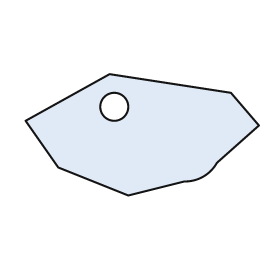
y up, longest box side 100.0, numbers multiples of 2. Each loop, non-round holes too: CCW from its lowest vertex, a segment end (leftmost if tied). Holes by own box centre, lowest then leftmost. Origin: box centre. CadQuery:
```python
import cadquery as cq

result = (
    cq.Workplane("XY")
    .moveTo(-6.0, -26.0)
    .lineTo(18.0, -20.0)
    .threePointArc((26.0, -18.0), (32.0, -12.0))
    .lineTo(50.0, 4.0)
    .lineTo(38.0, 18.0)
    .lineTo(-14.0, 26.0)
    .lineTo(-50.0, 6.0)
    .lineTo(-36.0, -14.0)
    .close()
    .moveTo(-12.0, 12.0)
    .circle(6.0)
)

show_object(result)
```